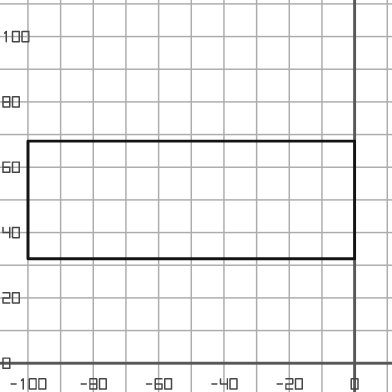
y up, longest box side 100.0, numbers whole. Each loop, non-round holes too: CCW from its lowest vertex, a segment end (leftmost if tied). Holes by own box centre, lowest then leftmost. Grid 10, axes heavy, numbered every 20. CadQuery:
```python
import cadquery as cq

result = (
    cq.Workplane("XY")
    .moveTo(-100.0, 32.0)
    .lineTo(0.0, 32.0)
    .lineTo(0.0, 68.0)
    .lineTo(-100.0, 68.0)
    .close()
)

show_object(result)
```